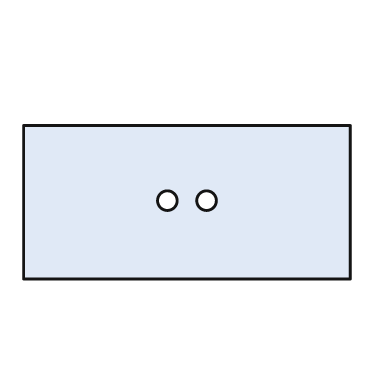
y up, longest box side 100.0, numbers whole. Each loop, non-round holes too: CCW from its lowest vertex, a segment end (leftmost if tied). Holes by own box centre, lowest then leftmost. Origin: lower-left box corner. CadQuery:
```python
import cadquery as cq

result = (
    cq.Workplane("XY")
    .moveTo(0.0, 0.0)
    .lineTo(100.0, 0.0)
    .lineTo(100.0, 47.0)
    .lineTo(0.0, 47.0)
    .close()
    .moveTo(44.0, 24.0)
    .circle(3.0)
    .moveTo(56.0, 24.0)
    .circle(3.0)
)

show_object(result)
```